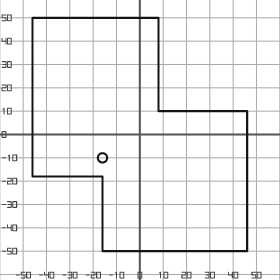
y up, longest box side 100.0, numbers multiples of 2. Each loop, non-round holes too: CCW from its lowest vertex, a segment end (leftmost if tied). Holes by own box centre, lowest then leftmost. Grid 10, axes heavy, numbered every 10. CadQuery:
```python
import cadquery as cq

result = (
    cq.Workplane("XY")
    .moveTo(-16.0, -50.0)
    .lineTo(46.0, -50.0)
    .lineTo(46.0, 10.0)
    .lineTo(8.0, 10.0)
    .lineTo(8.0, 50.0)
    .lineTo(-46.0, 50.0)
    .lineTo(-46.0, -18.0)
    .lineTo(-16.0, -18.0)
    .close()
    .moveTo(-16.0, -10.0)
    .circle(2.0)
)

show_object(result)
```